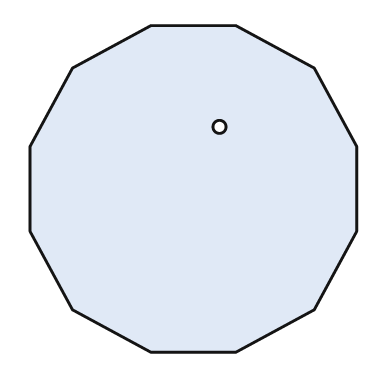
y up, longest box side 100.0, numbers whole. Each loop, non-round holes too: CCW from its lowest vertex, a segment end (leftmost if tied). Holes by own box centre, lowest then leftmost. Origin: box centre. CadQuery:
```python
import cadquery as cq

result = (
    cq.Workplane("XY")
    .moveTo(-13.0, -50.0)
    .lineTo(13.0, -50.0)
    .lineTo(37.0, -37.0)
    .lineTo(50.0, -13.0)
    .lineTo(50.0, 13.0)
    .lineTo(37.0, 37.0)
    .lineTo(13.0, 50.0)
    .lineTo(-13.0, 50.0)
    .lineTo(-37.0, 37.0)
    .lineTo(-50.0, 13.0)
    .lineTo(-50.0, -13.0)
    .lineTo(-37.0, -37.0)
    .close()
    .moveTo(8.0, 19.0)
    .circle(2.0)
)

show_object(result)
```